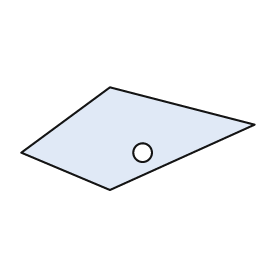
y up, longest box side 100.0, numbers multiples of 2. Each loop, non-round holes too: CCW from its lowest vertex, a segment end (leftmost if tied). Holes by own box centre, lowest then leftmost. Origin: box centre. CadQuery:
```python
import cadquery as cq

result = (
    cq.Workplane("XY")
    .moveTo(-12.0, -22.0)
    .lineTo(50.0, 6.0)
    .lineTo(-12.0, 22.0)
    .lineTo(-50.0, -6.0)
    .close()
    .moveTo(2.0, -6.0)
    .circle(4.0)
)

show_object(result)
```